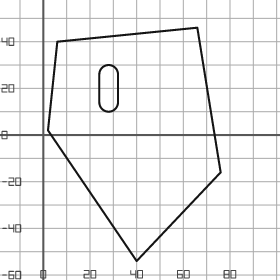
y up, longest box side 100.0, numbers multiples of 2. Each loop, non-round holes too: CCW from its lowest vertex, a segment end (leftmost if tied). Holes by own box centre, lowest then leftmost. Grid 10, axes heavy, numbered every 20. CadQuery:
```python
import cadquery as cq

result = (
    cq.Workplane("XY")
    .moveTo(40.0, -54.0)
    .lineTo(76.0, -16.0)
    .lineTo(66.0, 46.0)
    .lineTo(6.0, 40.0)
    .lineTo(2.0, 2.0)
    .close()
    .moveTo(24.0, 14.0)
    .threePointArc((28.0, 10.0), (32.0, 14.0))
    .lineTo(32.0, 26.0)
    .threePointArc((28.0, 30.0), (24.0, 26.0))
    .close()
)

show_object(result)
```